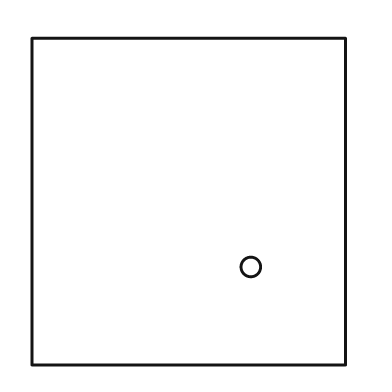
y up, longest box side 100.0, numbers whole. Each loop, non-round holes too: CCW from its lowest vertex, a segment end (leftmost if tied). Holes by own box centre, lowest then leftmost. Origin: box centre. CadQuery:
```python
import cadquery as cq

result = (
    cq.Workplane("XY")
    .moveTo(-48.0, -50.0)
    .lineTo(48.0, -50.0)
    .lineTo(48.0, 50.0)
    .lineTo(-48.0, 50.0)
    .close()
    .moveTo(19.0, -20.0)
    .circle(3.0)
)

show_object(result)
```